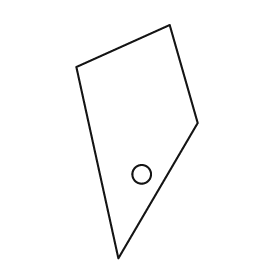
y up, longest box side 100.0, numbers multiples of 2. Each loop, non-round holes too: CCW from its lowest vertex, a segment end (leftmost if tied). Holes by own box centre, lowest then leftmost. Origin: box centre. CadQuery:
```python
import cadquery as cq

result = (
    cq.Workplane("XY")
    .moveTo(-8.0, -50.0)
    .lineTo(26.0, 8.0)
    .lineTo(14.0, 50.0)
    .lineTo(-26.0, 32.0)
    .close()
    .moveTo(2.0, -14.0)
    .circle(4.0)
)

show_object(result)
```